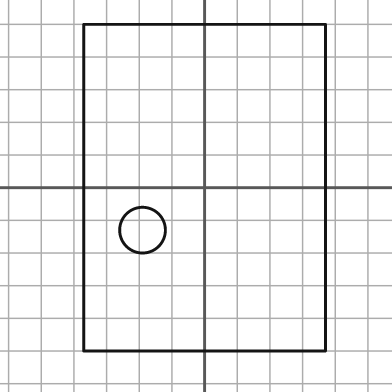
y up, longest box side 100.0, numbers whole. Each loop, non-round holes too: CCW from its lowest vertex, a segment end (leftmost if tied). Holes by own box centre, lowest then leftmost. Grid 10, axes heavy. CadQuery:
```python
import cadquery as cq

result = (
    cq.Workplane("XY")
    .moveTo(-37.0, -50.0)
    .lineTo(37.0, -50.0)
    .lineTo(37.0, 50.0)
    .lineTo(-37.0, 50.0)
    .close()
    .moveTo(-19.0, -13.0)
    .circle(7.0)
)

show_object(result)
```